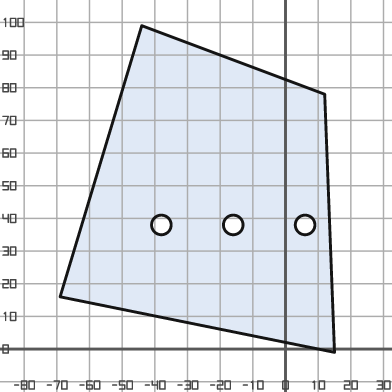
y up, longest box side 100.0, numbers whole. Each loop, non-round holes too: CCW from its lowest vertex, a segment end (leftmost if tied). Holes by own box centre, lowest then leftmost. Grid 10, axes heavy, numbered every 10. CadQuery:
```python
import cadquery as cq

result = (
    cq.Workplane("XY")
    .moveTo(15.0, -1.0)
    .lineTo(12.0, 78.0)
    .lineTo(-44.0, 99.0)
    .lineTo(-69.0, 16.0)
    .close()
    .moveTo(-38.0, 38.0)
    .circle(3.0)
    .moveTo(-16.0, 38.0)
    .circle(3.0)
    .moveTo(6.0, 38.0)
    .circle(3.0)
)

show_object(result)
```